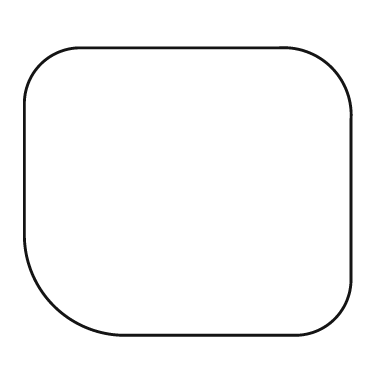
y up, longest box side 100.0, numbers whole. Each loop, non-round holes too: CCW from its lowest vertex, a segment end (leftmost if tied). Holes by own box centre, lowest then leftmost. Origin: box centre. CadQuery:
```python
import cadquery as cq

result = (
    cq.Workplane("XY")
    .moveTo(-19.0, -44.0)
    .lineTo(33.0, -44.0)
    .threePointArc((45.0, -39.0), (50.0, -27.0))
    .lineTo(50.0, 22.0)
    .threePointArc((44.0, 38.0), (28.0, 44.0))
    .lineTo(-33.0, 44.0)
    .threePointArc((-45.0, 39.0), (-50.0, 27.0))
    .lineTo(-50.0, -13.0)
    .threePointArc((-41.0, -35.0), (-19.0, -44.0))
    .close()
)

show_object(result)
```